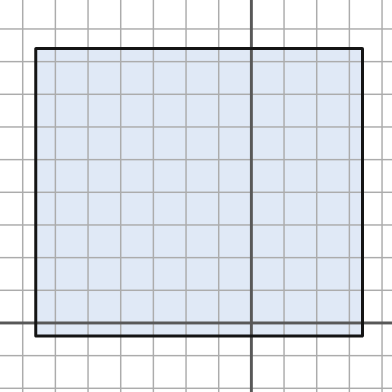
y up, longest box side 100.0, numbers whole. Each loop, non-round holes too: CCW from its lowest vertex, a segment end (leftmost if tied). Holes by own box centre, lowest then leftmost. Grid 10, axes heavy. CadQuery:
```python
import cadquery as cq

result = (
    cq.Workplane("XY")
    .moveTo(-66.0, -4.0)
    .lineTo(34.0, -4.0)
    .lineTo(34.0, 84.0)
    .lineTo(-66.0, 84.0)
    .close()
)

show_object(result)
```